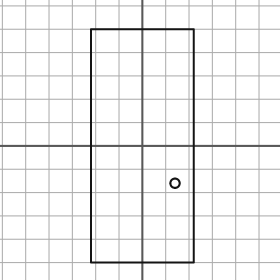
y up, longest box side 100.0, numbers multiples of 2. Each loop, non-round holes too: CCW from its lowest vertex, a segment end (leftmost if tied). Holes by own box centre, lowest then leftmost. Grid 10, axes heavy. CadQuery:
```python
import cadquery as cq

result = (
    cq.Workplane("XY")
    .moveTo(-22.0, -50.0)
    .lineTo(22.0, -50.0)
    .lineTo(22.0, 50.0)
    .lineTo(-22.0, 50.0)
    .close()
    .moveTo(14.0, -16.0)
    .circle(2.0)
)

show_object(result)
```